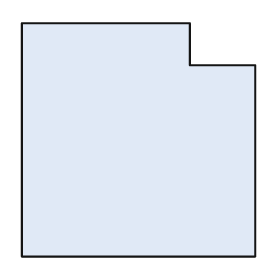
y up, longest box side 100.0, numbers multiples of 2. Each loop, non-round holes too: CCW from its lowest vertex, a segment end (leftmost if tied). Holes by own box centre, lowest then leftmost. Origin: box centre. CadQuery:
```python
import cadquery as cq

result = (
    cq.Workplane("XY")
    .moveTo(-50.0, -50.0)
    .lineTo(50.0, -50.0)
    .lineTo(50.0, 32.0)
    .lineTo(22.0, 32.0)
    .lineTo(22.0, 50.0)
    .lineTo(-50.0, 50.0)
    .close()
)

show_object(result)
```